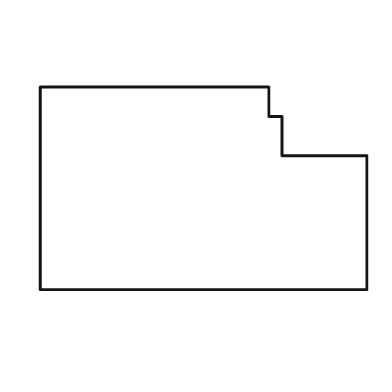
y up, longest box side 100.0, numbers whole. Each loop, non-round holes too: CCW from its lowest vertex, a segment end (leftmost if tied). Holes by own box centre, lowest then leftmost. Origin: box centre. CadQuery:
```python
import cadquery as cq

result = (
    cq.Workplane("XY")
    .moveTo(-50.0, -31.0)
    .lineTo(50.0, -31.0)
    .lineTo(50.0, 10.0)
    .lineTo(24.0, 10.0)
    .lineTo(24.0, 22.0)
    .lineTo(20.0, 22.0)
    .lineTo(20.0, 31.0)
    .lineTo(-50.0, 31.0)
    .close()
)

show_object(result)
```